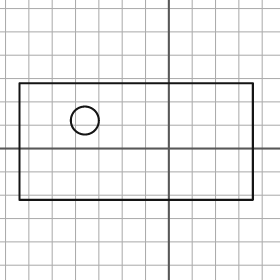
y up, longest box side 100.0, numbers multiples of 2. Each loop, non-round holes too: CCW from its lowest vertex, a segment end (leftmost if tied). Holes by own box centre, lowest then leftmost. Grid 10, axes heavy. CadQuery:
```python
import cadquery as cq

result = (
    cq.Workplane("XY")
    .moveTo(-64.0, -22.0)
    .lineTo(36.0, -22.0)
    .lineTo(36.0, 28.0)
    .lineTo(-64.0, 28.0)
    .close()
    .moveTo(-36.0, 12.0)
    .circle(6.0)
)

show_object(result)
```